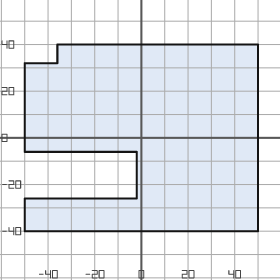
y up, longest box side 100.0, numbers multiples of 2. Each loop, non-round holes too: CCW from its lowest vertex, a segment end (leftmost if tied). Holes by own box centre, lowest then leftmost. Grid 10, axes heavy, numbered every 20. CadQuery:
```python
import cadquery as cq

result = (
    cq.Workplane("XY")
    .moveTo(-50.0, -40.0)
    .lineTo(50.0, -40.0)
    .lineTo(50.0, 40.0)
    .lineTo(-36.0, 40.0)
    .lineTo(-36.0, 32.0)
    .lineTo(-50.0, 32.0)
    .lineTo(-50.0, -6.0)
    .lineTo(-2.0, -6.0)
    .lineTo(-2.0, -26.0)
    .lineTo(-50.0, -26.0)
    .close()
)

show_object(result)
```